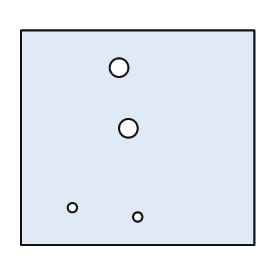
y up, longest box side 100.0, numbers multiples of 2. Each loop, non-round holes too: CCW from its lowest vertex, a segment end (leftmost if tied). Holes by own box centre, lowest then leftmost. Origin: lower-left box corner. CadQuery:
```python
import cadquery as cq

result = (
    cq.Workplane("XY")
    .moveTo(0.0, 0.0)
    .lineTo(100.0, 0.0)
    .lineTo(100.0, 92.0)
    .lineTo(0.0, 92.0)
    .close()
    .moveTo(50.0, 12.0)
    .circle(2.0)
    .moveTo(22.0, 16.0)
    .circle(2.0)
    .moveTo(46.0, 50.0)
    .circle(4.0)
    .moveTo(42.0, 76.0)
    .circle(4.0)
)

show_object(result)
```